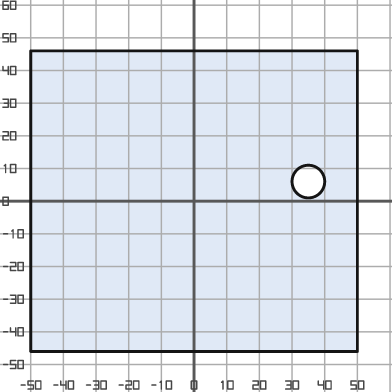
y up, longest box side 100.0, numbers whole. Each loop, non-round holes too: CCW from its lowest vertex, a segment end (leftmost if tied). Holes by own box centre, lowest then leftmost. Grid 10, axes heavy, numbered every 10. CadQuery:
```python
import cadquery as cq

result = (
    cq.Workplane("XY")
    .moveTo(-50.0, -46.0)
    .lineTo(50.0, -46.0)
    .lineTo(50.0, 46.0)
    .lineTo(-50.0, 46.0)
    .close()
    .moveTo(35.0, 6.0)
    .circle(5.0)
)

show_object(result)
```